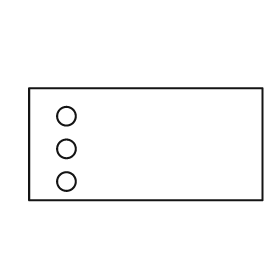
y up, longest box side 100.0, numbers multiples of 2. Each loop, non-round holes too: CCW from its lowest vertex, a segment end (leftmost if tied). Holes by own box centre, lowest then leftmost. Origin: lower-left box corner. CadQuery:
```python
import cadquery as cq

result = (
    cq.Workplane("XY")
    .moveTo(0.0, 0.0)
    .lineTo(100.0, 0.0)
    .lineTo(100.0, 48.0)
    .lineTo(0.0, 48.0)
    .close()
    .moveTo(16.0, 8.0)
    .circle(4.0)
    .moveTo(16.0, 22.0)
    .circle(4.0)
    .moveTo(16.0, 36.0)
    .circle(4.0)
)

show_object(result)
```